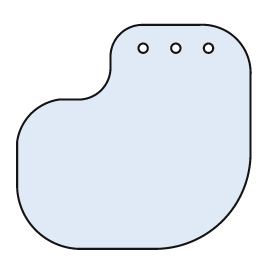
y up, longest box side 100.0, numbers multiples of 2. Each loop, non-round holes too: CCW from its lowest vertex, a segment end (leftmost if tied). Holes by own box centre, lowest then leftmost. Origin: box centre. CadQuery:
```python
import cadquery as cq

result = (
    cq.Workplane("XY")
    .moveTo(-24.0, -48.0)
    .lineTo(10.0, -48.0)
    .threePointArc((38.0, -36.0), (50.0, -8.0))
    .lineTo(50.0, 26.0)
    .threePointArc((44.0, 42.0), (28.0, 48.0))
    .lineTo(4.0, 48.0)
    .threePointArc((-6.0, 44.0), (-10.0, 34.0))
    .lineTo(-10.0, 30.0)
    .threePointArc((-14.0, 20.0), (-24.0, 16.0))
    .lineTo(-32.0, 16.0)
    .threePointArc((-44.0, 10.0), (-50.0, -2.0))
    .lineTo(-50.0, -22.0)
    .threePointArc((-42.0, -40.0), (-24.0, -48.0))
    .close()
    .moveTo(4.0, 38.0)
    .circle(2.0)
    .moveTo(18.0, 38.0)
    .circle(2.0)
    .moveTo(32.0, 38.0)
    .circle(2.0)
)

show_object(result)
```